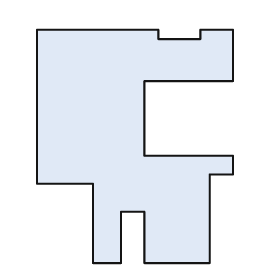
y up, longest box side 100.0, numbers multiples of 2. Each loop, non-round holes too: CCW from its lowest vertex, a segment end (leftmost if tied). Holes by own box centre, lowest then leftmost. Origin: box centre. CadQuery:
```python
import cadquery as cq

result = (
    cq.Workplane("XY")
    .moveTo(-18.0, -50.0)
    .lineTo(-6.0, -50.0)
    .lineTo(-6.0, -28.0)
    .lineTo(4.0, -28.0)
    .lineTo(4.0, -50.0)
    .lineTo(32.0, -50.0)
    .lineTo(32.0, -12.0)
    .lineTo(42.0, -12.0)
    .lineTo(42.0, -4.0)
    .lineTo(4.0, -4.0)
    .lineTo(4.0, 28.0)
    .lineTo(42.0, 28.0)
    .lineTo(42.0, 50.0)
    .lineTo(28.0, 50.0)
    .lineTo(28.0, 46.0)
    .lineTo(10.0, 46.0)
    .lineTo(10.0, 50.0)
    .lineTo(-42.0, 50.0)
    .lineTo(-42.0, -16.0)
    .lineTo(-18.0, -16.0)
    .close()
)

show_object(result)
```